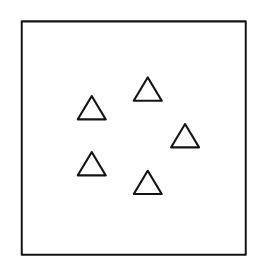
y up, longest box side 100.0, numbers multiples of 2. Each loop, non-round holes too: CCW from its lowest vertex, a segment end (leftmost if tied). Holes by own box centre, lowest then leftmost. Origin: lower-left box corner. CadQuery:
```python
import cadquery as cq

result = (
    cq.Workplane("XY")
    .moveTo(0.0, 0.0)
    .lineTo(96.0, 0.0)
    .lineTo(96.0, 100.0)
    .lineTo(0.0, 100.0)
    .close()
    .moveTo(48.0, 26.0)
    .lineTo(60.0, 26.0)
    .lineTo(54.0, 36.0)
    .close()
    .moveTo(24.0, 34.0)
    .lineTo(36.0, 34.0)
    .lineTo(30.0, 44.0)
    .close()
    .moveTo(64.0, 46.0)
    .lineTo(76.0, 46.0)
    .lineTo(70.0, 56.0)
    .close()
    .moveTo(24.0, 58.0)
    .lineTo(36.0, 58.0)
    .lineTo(30.0, 68.0)
    .close()
    .moveTo(48.0, 66.0)
    .lineTo(60.0, 66.0)
    .lineTo(54.0, 76.0)
    .close()
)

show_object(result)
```